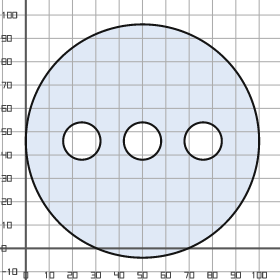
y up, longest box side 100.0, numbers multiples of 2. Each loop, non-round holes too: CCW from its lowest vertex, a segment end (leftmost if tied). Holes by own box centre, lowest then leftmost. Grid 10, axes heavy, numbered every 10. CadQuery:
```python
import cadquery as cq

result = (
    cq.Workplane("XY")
    .moveTo(50.0, 46.0)
    .circle(50.0)
    .moveTo(24.0, 46.0)
    .circle(8.0)
    .moveTo(50.0, 46.0)
    .circle(8.0)
    .moveTo(76.0, 46.0)
    .circle(8.0)
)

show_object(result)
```